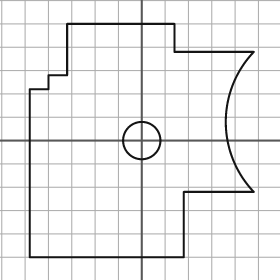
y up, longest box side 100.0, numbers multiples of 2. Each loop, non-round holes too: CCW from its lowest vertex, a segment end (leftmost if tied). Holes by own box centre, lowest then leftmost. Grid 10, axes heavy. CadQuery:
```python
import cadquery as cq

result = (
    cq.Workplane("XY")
    .moveTo(-48.0, -50.0)
    .lineTo(18.0, -50.0)
    .lineTo(18.0, -22.0)
    .lineTo(48.0, -22.0)
    .threePointArc((36.0, 8.0), (48.0, 38.0))
    .lineTo(14.0, 38.0)
    .lineTo(14.0, 50.0)
    .lineTo(-32.0, 50.0)
    .lineTo(-32.0, 28.0)
    .lineTo(-40.0, 28.0)
    .lineTo(-40.0, 22.0)
    .lineTo(-48.0, 22.0)
    .close()
    .moveTo(0.0, 0.0)
    .circle(8.0)
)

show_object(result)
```